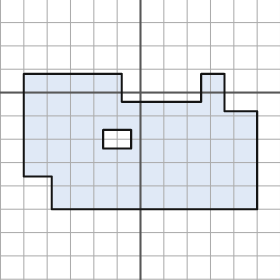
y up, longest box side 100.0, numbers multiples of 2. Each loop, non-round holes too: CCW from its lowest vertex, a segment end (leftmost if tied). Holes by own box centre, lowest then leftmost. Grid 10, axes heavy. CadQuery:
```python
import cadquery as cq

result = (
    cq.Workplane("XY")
    .moveTo(-38.0, -50.0)
    .lineTo(50.0, -50.0)
    .lineTo(50.0, -8.0)
    .lineTo(36.0, -8.0)
    .lineTo(36.0, 8.0)
    .lineTo(26.0, 8.0)
    .lineTo(26.0, -4.0)
    .lineTo(-8.0, -4.0)
    .lineTo(-8.0, 8.0)
    .lineTo(-50.0, 8.0)
    .lineTo(-50.0, -36.0)
    .lineTo(-38.0, -36.0)
    .close()
    .moveTo(-16.0, -24.0)
    .lineTo(-4.0, -24.0)
    .lineTo(-4.0, -16.0)
    .lineTo(-16.0, -16.0)
    .close()
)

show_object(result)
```